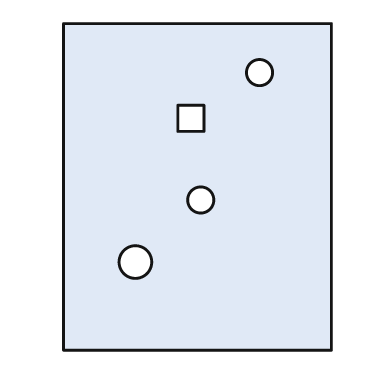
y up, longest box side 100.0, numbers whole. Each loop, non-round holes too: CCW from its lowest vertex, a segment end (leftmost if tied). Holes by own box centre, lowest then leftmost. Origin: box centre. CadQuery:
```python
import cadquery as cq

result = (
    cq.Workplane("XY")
    .moveTo(-41.0, -50.0)
    .lineTo(41.0, -50.0)
    .lineTo(41.0, 50.0)
    .lineTo(-41.0, 50.0)
    .close()
    .moveTo(-19.0, -23.0)
    .circle(5.0)
    .moveTo(1.0, -4.0)
    .circle(4.0)
    .moveTo(-6.0, 17.0)
    .lineTo(2.0, 17.0)
    .lineTo(2.0, 25.0)
    .lineTo(-6.0, 25.0)
    .close()
    .moveTo(19.0, 35.0)
    .circle(4.0)
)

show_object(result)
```